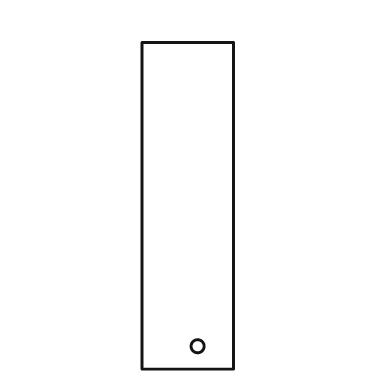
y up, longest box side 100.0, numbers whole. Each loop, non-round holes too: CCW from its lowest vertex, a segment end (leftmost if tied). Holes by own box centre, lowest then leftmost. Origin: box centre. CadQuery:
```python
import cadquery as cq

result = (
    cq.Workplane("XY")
    .moveTo(-14.0, -50.0)
    .lineTo(14.0, -50.0)
    .lineTo(14.0, 50.0)
    .lineTo(-14.0, 50.0)
    .close()
    .moveTo(3.0, -43.0)
    .circle(2.0)
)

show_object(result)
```